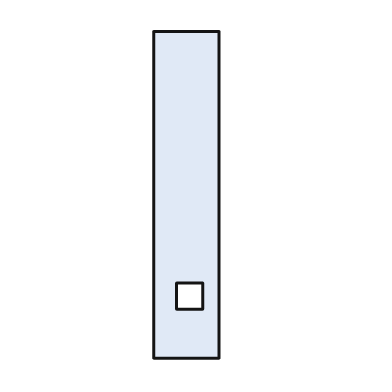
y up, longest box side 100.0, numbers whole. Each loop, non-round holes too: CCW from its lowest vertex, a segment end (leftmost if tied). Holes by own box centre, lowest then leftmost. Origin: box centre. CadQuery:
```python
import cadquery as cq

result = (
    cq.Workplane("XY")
    .moveTo(-10.0, -50.0)
    .lineTo(10.0, -50.0)
    .lineTo(10.0, 50.0)
    .lineTo(-10.0, 50.0)
    .close()
    .moveTo(-3.0, -35.0)
    .lineTo(5.0, -35.0)
    .lineTo(5.0, -27.0)
    .lineTo(-3.0, -27.0)
    .close()
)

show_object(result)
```